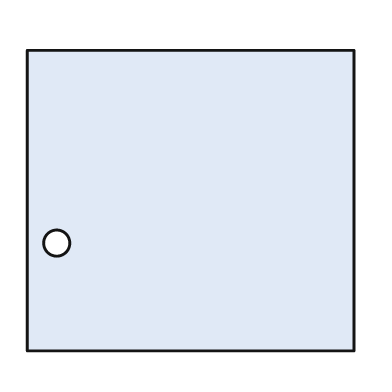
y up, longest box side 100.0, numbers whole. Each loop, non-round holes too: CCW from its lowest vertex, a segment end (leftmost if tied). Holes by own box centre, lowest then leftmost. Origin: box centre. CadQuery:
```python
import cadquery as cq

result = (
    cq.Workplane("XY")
    .moveTo(-50.0, -46.0)
    .lineTo(50.0, -46.0)
    .lineTo(50.0, 46.0)
    .lineTo(-50.0, 46.0)
    .close()
    .moveTo(-41.0, -13.0)
    .circle(4.0)
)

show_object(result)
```